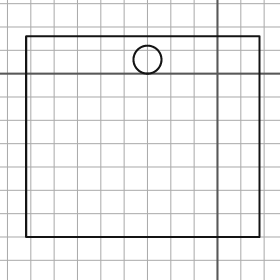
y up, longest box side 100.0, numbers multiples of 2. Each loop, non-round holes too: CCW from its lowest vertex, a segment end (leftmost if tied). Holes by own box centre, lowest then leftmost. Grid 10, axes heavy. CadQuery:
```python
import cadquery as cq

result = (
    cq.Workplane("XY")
    .moveTo(-82.0, -70.0)
    .lineTo(18.0, -70.0)
    .lineTo(18.0, 16.0)
    .lineTo(-82.0, 16.0)
    .close()
    .moveTo(-30.0, 6.0)
    .circle(6.0)
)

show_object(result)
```